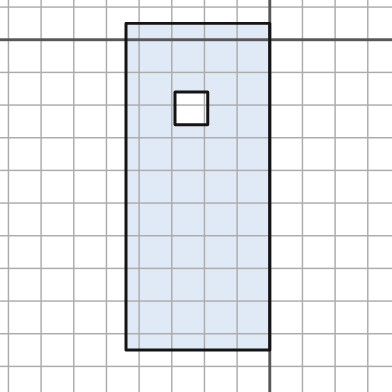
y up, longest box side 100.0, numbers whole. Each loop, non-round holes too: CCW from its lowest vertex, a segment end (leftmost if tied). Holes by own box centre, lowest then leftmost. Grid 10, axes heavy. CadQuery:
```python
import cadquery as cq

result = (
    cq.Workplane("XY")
    .moveTo(-44.0, -95.0)
    .lineTo(0.0, -95.0)
    .lineTo(0.0, 5.0)
    .lineTo(-44.0, 5.0)
    .close()
    .moveTo(-29.0, -26.0)
    .lineTo(-19.0, -26.0)
    .lineTo(-19.0, -16.0)
    .lineTo(-29.0, -16.0)
    .close()
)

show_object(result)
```